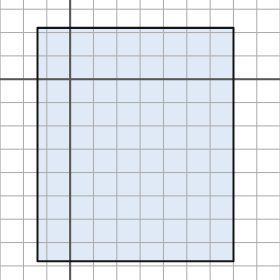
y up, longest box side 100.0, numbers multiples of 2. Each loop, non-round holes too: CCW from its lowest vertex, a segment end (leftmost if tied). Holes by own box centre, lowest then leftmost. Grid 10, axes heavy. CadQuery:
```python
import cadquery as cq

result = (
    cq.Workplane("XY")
    .moveTo(-14.0, -78.0)
    .lineTo(70.0, -78.0)
    .lineTo(70.0, 22.0)
    .lineTo(-14.0, 22.0)
    .close()
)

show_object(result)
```